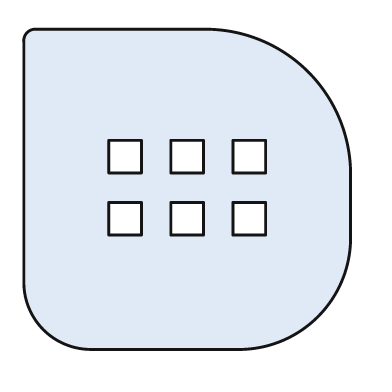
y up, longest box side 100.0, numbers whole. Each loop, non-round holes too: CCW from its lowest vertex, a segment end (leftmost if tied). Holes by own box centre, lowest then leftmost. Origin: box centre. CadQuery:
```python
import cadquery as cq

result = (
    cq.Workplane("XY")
    .moveTo(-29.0, -49.0)
    .lineTo(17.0, -49.0)
    .threePointArc((40.0, -39.0), (50.0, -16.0))
    .lineTo(50.0, 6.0)
    .threePointArc((37.0, 36.0), (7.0, 49.0))
    .lineTo(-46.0, 49.0)
    .threePointArc((-49.0, 48.0), (-50.0, 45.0))
    .lineTo(-50.0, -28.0)
    .threePointArc((-44.0, -43.0), (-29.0, -49.0))
    .close()
    .moveTo(-24.0, -14.0)
    .lineTo(-14.0, -14.0)
    .lineTo(-14.0, -4.0)
    .lineTo(-24.0, -4.0)
    .close()
    .moveTo(-5.0, -14.0)
    .lineTo(5.0, -14.0)
    .lineTo(5.0, -4.0)
    .lineTo(-5.0, -4.0)
    .close()
    .moveTo(14.0, -14.0)
    .lineTo(24.0, -14.0)
    .lineTo(24.0, -4.0)
    .lineTo(14.0, -4.0)
    .close()
    .moveTo(-24.0, 5.0)
    .lineTo(-14.0, 5.0)
    .lineTo(-14.0, 15.0)
    .lineTo(-24.0, 15.0)
    .close()
    .moveTo(-5.0, 5.0)
    .lineTo(5.0, 5.0)
    .lineTo(5.0, 15.0)
    .lineTo(-5.0, 15.0)
    .close()
    .moveTo(14.0, 5.0)
    .lineTo(24.0, 5.0)
    .lineTo(24.0, 15.0)
    .lineTo(14.0, 15.0)
    .close()
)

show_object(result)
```